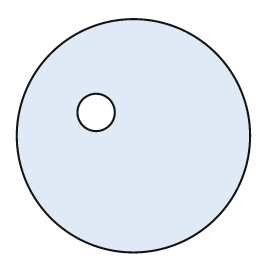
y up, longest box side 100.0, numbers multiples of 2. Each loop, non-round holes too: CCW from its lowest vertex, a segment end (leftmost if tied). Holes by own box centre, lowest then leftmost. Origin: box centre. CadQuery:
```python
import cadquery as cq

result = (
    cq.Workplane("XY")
    .moveTo(0.0, 0.0)
    .circle(50.0)
    .moveTo(-16.0, 10.0)
    .circle(8.0)
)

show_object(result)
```